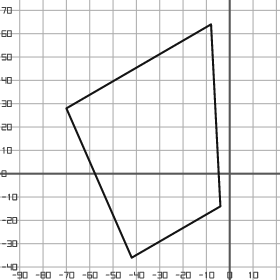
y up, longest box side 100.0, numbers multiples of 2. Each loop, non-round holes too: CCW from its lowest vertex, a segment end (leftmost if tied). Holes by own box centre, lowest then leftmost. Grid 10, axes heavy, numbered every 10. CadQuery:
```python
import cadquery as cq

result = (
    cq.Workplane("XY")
    .moveTo(-42.0, -36.0)
    .lineTo(-4.0, -14.0)
    .lineTo(-8.0, 64.0)
    .lineTo(-70.0, 28.0)
    .close()
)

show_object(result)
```